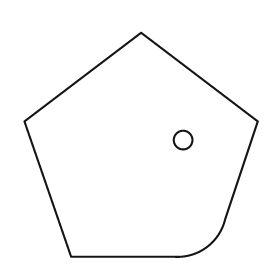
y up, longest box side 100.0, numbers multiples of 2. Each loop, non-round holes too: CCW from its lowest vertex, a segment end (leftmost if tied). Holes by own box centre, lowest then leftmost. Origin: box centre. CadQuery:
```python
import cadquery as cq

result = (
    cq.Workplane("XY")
    .moveTo(-30.0, -48.0)
    .lineTo(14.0, -48.0)
    .threePointArc((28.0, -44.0), (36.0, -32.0))
    .lineTo(50.0, 10.0)
    .lineTo(0.0, 48.0)
    .lineTo(-50.0, 10.0)
    .close()
    .moveTo(18.0, 2.0)
    .circle(4.0)
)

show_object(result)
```